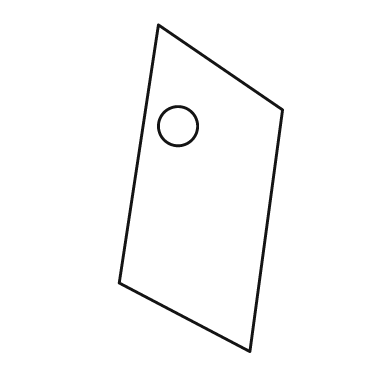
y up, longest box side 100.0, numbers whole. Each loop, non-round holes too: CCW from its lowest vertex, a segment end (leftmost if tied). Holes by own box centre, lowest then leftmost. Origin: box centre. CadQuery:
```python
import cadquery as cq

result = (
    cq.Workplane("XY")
    .moveTo(15.0, -50.0)
    .lineTo(25.0, 24.0)
    .lineTo(-13.0, 50.0)
    .lineTo(-25.0, -29.0)
    .close()
    .moveTo(-7.0, 19.0)
    .circle(6.0)
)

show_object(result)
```